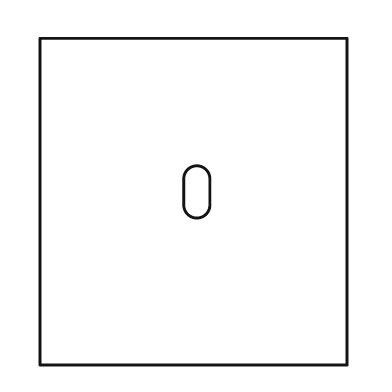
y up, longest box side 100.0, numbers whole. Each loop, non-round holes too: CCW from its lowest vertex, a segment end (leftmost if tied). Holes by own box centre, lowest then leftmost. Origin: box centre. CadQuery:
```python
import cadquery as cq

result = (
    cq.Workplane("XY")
    .moveTo(-47.0, -50.0)
    .lineTo(47.0, -50.0)
    .lineTo(47.0, 50.0)
    .lineTo(-47.0, 50.0)
    .close()
    .moveTo(-3.0, -1.0)
    .threePointArc((1.0, -5.0), (5.0, -1.0))
    .lineTo(5.0, 7.0)
    .threePointArc((1.0, 11.0), (-3.0, 7.0))
    .close()
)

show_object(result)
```